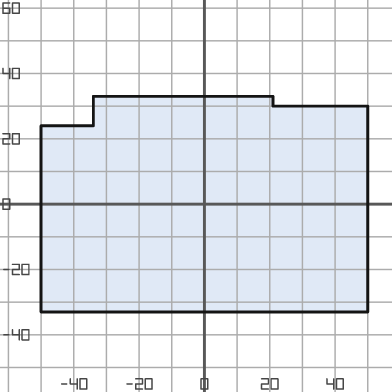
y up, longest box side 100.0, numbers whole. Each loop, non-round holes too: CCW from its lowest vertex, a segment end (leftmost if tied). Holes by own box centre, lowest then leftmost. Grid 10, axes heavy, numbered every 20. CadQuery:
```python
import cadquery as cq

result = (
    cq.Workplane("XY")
    .moveTo(-50.0, -33.0)
    .lineTo(50.0, -33.0)
    .lineTo(50.0, 30.0)
    .lineTo(21.0, 30.0)
    .lineTo(21.0, 33.0)
    .lineTo(-34.0, 33.0)
    .lineTo(-34.0, 24.0)
    .lineTo(-50.0, 24.0)
    .close()
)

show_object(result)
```